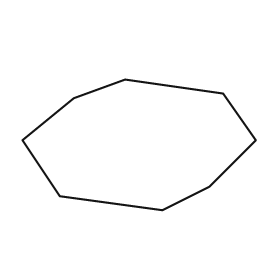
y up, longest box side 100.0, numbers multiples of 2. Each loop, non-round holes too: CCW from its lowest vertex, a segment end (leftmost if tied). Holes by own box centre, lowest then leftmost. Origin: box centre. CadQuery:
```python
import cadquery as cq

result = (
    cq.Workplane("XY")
    .moveTo(10.0, -28.0)
    .lineTo(30.0, -18.0)
    .lineTo(50.0, 2.0)
    .lineTo(36.0, 22.0)
    .lineTo(-6.0, 28.0)
    .lineTo(-28.0, 20.0)
    .lineTo(-50.0, 2.0)
    .lineTo(-34.0, -22.0)
    .close()
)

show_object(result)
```